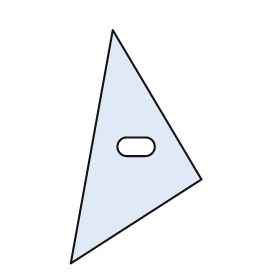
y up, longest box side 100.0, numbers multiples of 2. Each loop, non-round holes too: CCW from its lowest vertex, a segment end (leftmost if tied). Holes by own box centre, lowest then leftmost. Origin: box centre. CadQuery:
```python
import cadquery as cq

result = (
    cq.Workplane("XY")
    .moveTo(-28.0, -50.0)
    .lineTo(28.0, -14.0)
    .lineTo(-10.0, 50.0)
    .close()
    .moveTo(-4.0, -4.0)
    .lineTo(4.0, -4.0)
    .threePointArc((8.0, 0.0), (4.0, 4.0))
    .lineTo(-4.0, 4.0)
    .threePointArc((-8.0, 0.0), (-4.0, -4.0))
    .close()
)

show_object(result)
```